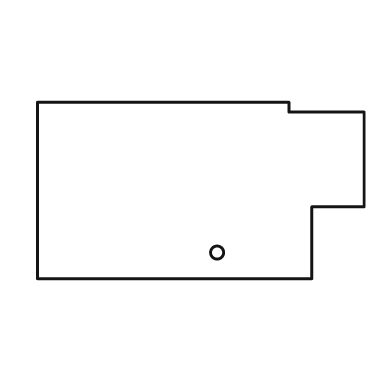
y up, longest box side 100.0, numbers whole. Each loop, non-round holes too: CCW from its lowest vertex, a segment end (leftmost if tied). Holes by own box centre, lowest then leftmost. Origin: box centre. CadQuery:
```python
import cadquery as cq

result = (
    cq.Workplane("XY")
    .moveTo(-50.0, -27.0)
    .lineTo(34.0, -27.0)
    .lineTo(34.0, -5.0)
    .lineTo(50.0, -5.0)
    .lineTo(50.0, 24.0)
    .lineTo(27.0, 24.0)
    .lineTo(27.0, 27.0)
    .lineTo(-50.0, 27.0)
    .close()
    .moveTo(5.0, -19.0)
    .circle(2.0)
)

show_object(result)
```